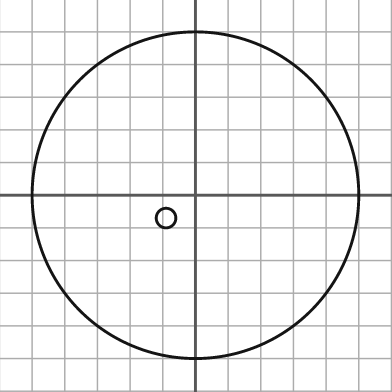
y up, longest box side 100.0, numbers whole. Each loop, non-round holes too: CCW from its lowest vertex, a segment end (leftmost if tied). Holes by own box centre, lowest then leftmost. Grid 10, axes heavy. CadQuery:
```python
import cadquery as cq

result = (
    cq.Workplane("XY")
    .moveTo(0.0, 0.0)
    .circle(50.0)
    .moveTo(-9.0, -7.0)
    .circle(3.0)
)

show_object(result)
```